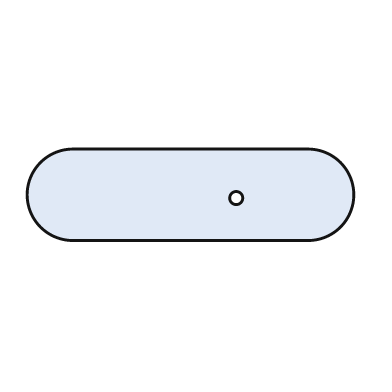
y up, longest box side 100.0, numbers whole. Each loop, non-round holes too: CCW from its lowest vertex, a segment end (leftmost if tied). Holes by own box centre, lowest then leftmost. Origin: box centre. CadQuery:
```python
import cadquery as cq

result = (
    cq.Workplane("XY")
    .moveTo(-36.0, -14.0)
    .lineTo(36.0, -14.0)
    .threePointArc((50.0, 0.0), (36.0, 14.0))
    .lineTo(-36.0, 14.0)
    .threePointArc((-50.0, 0.0), (-36.0, -14.0))
    .close()
    .moveTo(14.0, -1.0)
    .circle(2.0)
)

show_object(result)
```